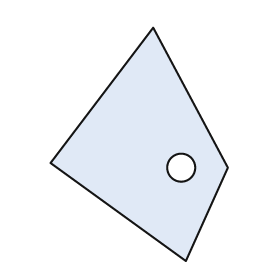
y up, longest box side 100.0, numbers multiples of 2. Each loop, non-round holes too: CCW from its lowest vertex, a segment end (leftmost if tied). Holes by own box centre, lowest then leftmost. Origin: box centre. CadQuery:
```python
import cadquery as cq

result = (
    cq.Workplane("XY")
    .moveTo(20.0, -50.0)
    .lineTo(38.0, -10.0)
    .lineTo(6.0, 50.0)
    .lineTo(-38.0, -8.0)
    .close()
    .moveTo(18.0, -10.0)
    .circle(6.0)
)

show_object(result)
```